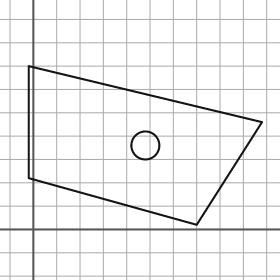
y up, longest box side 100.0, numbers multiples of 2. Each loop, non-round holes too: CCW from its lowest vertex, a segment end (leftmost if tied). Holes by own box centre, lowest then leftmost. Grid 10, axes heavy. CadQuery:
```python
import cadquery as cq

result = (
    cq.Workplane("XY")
    .moveTo(70.0, 2.0)
    .lineTo(98.0, 46.0)
    .lineTo(-2.0, 70.0)
    .lineTo(-2.0, 22.0)
    .close()
    .moveTo(48.0, 36.0)
    .circle(6.0)
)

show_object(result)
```